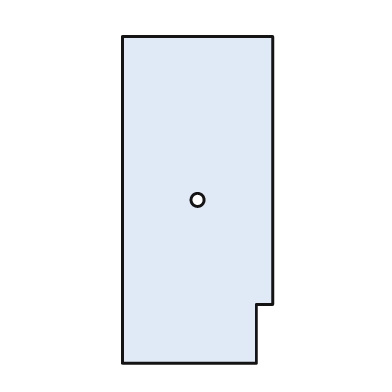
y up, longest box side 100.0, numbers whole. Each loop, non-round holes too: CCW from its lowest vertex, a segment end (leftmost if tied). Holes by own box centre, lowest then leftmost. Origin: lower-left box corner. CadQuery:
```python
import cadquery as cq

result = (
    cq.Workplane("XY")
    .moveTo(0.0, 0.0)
    .lineTo(41.0, 0.0)
    .lineTo(41.0, 18.0)
    .lineTo(46.0, 18.0)
    .lineTo(46.0, 100.0)
    .lineTo(0.0, 100.0)
    .close()
    .moveTo(23.0, 50.0)
    .circle(2.0)
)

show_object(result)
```